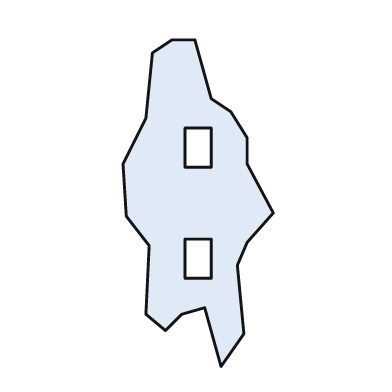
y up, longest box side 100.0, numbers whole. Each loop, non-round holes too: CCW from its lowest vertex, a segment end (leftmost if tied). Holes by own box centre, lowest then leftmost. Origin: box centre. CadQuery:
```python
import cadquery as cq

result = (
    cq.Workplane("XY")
    .moveTo(7.0, -50.0)
    .lineTo(14.0, -40.0)
    .lineTo(12.0, -19.0)
    .lineTo(15.0, -12.0)
    .lineTo(23.0, -3.0)
    .lineTo(15.0, 12.0)
    .lineTo(15.0, 20.0)
    .lineTo(10.0, 28.0)
    .lineTo(4.0, 32.0)
    .lineTo(-1.0, 50.0)
    .lineTo(-8.0, 50.0)
    .lineTo(-14.0, 46.0)
    .lineTo(-16.0, 26.0)
    .lineTo(-23.0, 12.0)
    .lineTo(-22.0, -4.0)
    .lineTo(-15.0, -13.0)
    .lineTo(-16.0, -34.0)
    .lineTo(-10.0, -39.0)
    .lineTo(-5.0, -34.0)
    .lineTo(2.0, -32.0)
    .close()
    .moveTo(-4.0, -23.0)
    .lineTo(4.0, -23.0)
    .lineTo(4.0, -11.0)
    .lineTo(-4.0, -11.0)
    .close()
    .moveTo(-4.0, 11.0)
    .lineTo(4.0, 11.0)
    .lineTo(4.0, 23.0)
    .lineTo(-4.0, 23.0)
    .close()
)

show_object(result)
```